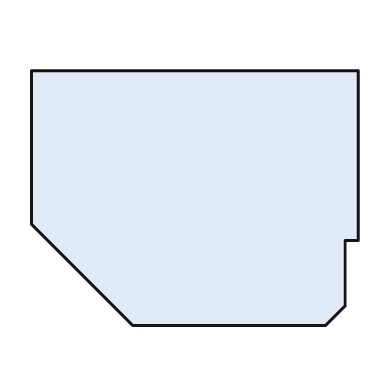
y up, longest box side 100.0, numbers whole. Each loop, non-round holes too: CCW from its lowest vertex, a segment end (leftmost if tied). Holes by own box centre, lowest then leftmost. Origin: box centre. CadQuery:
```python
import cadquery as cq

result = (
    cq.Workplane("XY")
    .moveTo(-19.0, -39.0)
    .lineTo(40.0, -39.0)
    .lineTo(46.0, -33.0)
    .lineTo(46.0, -13.0)
    .lineTo(50.0, -13.0)
    .lineTo(50.0, 39.0)
    .lineTo(-50.0, 39.0)
    .lineTo(-50.0, -8.0)
    .close()
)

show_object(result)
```